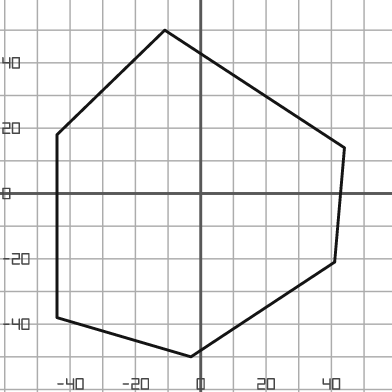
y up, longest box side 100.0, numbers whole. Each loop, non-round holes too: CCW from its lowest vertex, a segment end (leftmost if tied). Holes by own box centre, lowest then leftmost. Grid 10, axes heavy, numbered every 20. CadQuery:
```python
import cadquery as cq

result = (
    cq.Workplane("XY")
    .moveTo(-3.0, -50.0)
    .lineTo(41.0, -21.0)
    .lineTo(44.0, 14.0)
    .lineTo(-11.0, 50.0)
    .lineTo(-44.0, 18.0)
    .lineTo(-44.0, -38.0)
    .close()
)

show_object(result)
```